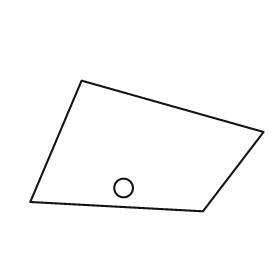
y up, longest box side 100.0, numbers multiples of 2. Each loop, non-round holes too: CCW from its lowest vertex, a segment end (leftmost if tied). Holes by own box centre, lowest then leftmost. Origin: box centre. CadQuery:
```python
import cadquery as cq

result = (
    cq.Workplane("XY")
    .moveTo(24.0, -28.0)
    .lineTo(50.0, 6.0)
    .lineTo(-28.0, 28.0)
    .lineTo(-50.0, -24.0)
    .close()
    .moveTo(-10.0, -18.0)
    .circle(4.0)
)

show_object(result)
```